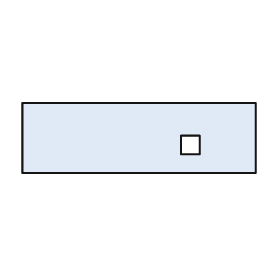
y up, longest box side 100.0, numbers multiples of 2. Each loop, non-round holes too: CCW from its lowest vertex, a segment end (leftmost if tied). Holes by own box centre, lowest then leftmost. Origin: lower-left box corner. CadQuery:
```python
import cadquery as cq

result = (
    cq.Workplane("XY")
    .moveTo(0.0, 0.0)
    .lineTo(100.0, 0.0)
    .lineTo(100.0, 30.0)
    .lineTo(0.0, 30.0)
    .close()
    .moveTo(68.0, 8.0)
    .lineTo(76.0, 8.0)
    .lineTo(76.0, 16.0)
    .lineTo(68.0, 16.0)
    .close()
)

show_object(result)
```